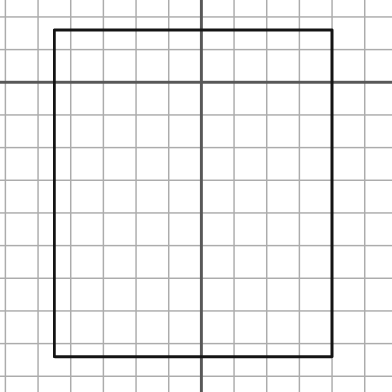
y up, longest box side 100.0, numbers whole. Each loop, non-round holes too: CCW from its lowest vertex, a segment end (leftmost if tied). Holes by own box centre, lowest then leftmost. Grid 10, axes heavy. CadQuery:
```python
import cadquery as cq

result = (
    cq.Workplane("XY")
    .moveTo(-45.0, -84.0)
    .lineTo(40.0, -84.0)
    .lineTo(40.0, 16.0)
    .lineTo(-45.0, 16.0)
    .close()
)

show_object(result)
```